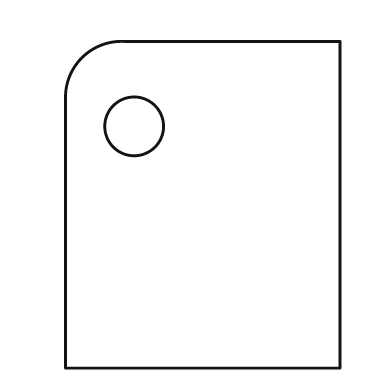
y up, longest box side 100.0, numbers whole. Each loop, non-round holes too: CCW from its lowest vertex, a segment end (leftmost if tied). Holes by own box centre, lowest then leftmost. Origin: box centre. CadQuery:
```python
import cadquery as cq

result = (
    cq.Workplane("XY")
    .moveTo(-42.0, -50.0)
    .lineTo(42.0, -50.0)
    .lineTo(42.0, 50.0)
    .lineTo(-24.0, 50.0)
    .threePointArc((-37.0, 45.0), (-42.0, 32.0))
    .close()
    .moveTo(-21.0, 24.0)
    .circle(9.0)
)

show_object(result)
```